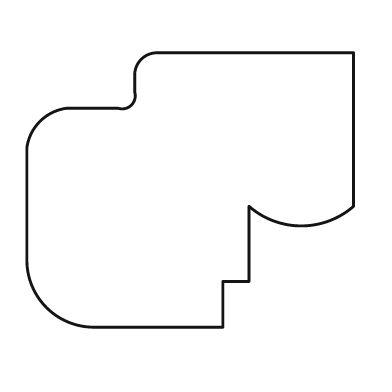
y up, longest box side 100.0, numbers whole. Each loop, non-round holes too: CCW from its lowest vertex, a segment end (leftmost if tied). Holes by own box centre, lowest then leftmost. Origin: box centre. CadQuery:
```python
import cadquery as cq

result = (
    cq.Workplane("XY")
    .moveTo(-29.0, -42.0)
    .lineTo(10.0, -42.0)
    .lineTo(10.0, -28.0)
    .lineTo(18.0, -28.0)
    .lineTo(18.0, -5.0)
    .threePointArc((34.0, -11.0), (50.0, -5.0))
    .lineTo(50.0, 42.0)
    .lineTo(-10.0, 42.0)
    .threePointArc((-15.0, 40.0), (-17.0, 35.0))
    .lineTo(-17.0, 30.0)
    .threePointArc((-18.0, 26.0), (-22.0, 25.0))
    .lineTo(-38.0, 25.0)
    .threePointArc((-46.0, 21.0), (-50.0, 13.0))
    .lineTo(-50.0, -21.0)
    .threePointArc((-44.0, -36.0), (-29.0, -42.0))
    .close()
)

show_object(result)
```